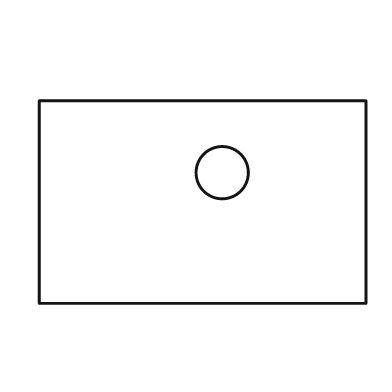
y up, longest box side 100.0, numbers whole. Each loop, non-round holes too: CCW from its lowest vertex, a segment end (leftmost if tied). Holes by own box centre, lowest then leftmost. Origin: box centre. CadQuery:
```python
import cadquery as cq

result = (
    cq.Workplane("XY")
    .moveTo(-50.0, -31.0)
    .lineTo(50.0, -31.0)
    .lineTo(50.0, 31.0)
    .lineTo(-50.0, 31.0)
    .close()
    .moveTo(6.0, 9.0)
    .circle(8.0)
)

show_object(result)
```